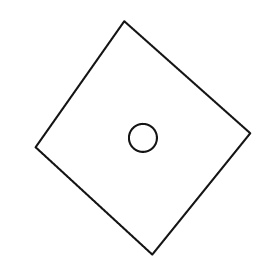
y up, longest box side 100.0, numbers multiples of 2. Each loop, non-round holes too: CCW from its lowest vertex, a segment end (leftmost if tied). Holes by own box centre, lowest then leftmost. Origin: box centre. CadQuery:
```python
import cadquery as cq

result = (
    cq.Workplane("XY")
    .moveTo(4.0, -50.0)
    .lineTo(46.0, 2.0)
    .lineTo(-8.0, 50.0)
    .lineTo(-46.0, -4.0)
    .close()
    .moveTo(0.0, 0.0)
    .circle(6.0)
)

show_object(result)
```